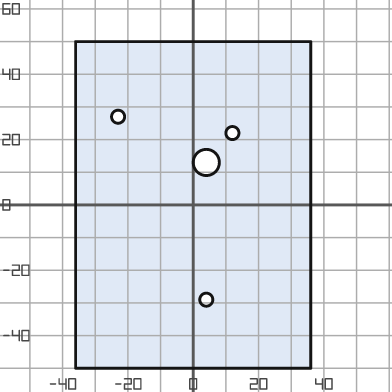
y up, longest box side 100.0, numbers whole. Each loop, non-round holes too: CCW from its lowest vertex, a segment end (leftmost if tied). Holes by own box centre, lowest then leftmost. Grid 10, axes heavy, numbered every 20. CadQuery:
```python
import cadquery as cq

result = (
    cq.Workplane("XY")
    .moveTo(-36.0, -50.0)
    .lineTo(36.0, -50.0)
    .lineTo(36.0, 50.0)
    .lineTo(-36.0, 50.0)
    .close()
    .moveTo(4.0, -29.0)
    .circle(2.0)
    .moveTo(4.0, 13.0)
    .circle(4.0)
    .moveTo(12.0, 22.0)
    .circle(2.0)
    .moveTo(-23.0, 27.0)
    .circle(2.0)
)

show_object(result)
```